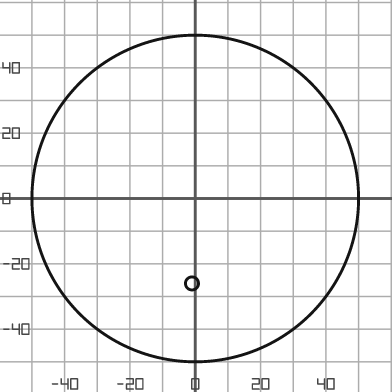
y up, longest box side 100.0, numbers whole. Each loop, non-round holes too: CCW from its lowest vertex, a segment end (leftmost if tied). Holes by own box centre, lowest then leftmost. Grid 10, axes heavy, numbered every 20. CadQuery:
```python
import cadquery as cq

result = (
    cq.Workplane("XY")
    .moveTo(0.0, 0.0)
    .circle(50.0)
    .moveTo(-1.0, -26.0)
    .circle(2.0)
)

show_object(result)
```